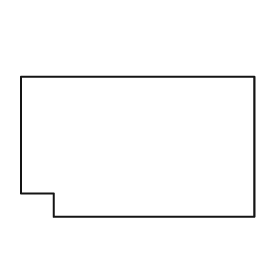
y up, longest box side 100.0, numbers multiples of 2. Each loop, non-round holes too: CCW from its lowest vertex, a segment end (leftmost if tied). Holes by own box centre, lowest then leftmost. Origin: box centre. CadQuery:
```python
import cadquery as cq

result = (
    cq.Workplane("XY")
    .moveTo(-36.0, -30.0)
    .lineTo(50.0, -30.0)
    .lineTo(50.0, 30.0)
    .lineTo(-50.0, 30.0)
    .lineTo(-50.0, -20.0)
    .lineTo(-36.0, -20.0)
    .close()
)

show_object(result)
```